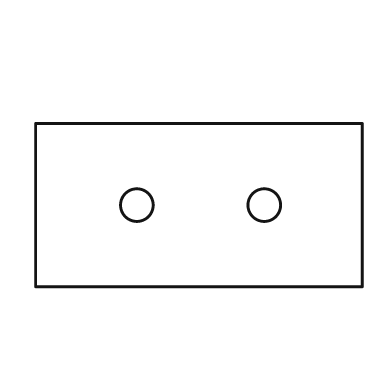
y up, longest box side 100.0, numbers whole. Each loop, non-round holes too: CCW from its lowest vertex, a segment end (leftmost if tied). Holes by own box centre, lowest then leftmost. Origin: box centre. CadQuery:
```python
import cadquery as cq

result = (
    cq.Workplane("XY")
    .moveTo(-50.0, -25.0)
    .lineTo(50.0, -25.0)
    .lineTo(50.0, 25.0)
    .lineTo(-50.0, 25.0)
    .close()
    .moveTo(-19.0, 0.0)
    .circle(5.0)
    .moveTo(20.0, 0.0)
    .circle(5.0)
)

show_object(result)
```